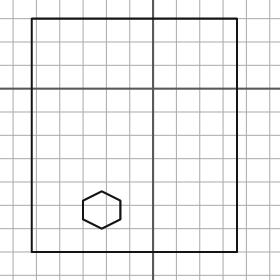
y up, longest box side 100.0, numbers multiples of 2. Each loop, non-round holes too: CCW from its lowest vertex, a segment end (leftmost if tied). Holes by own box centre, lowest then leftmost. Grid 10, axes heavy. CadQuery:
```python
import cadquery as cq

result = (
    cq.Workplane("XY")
    .moveTo(-52.0, -70.0)
    .lineTo(36.0, -70.0)
    .lineTo(36.0, 30.0)
    .lineTo(-52.0, 30.0)
    .close()
    .moveTo(-22.0, -60.0)
    .lineTo(-14.0, -56.0)
    .lineTo(-14.0, -48.0)
    .lineTo(-22.0, -44.0)
    .lineTo(-30.0, -48.0)
    .lineTo(-30.0, -56.0)
    .close()
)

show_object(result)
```